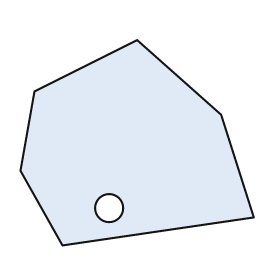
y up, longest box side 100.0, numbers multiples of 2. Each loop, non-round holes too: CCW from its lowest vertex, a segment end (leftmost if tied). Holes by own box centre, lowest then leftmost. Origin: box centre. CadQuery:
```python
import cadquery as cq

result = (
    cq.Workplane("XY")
    .moveTo(-32.0, -44.0)
    .lineTo(50.0, -32.0)
    .lineTo(36.0, 12.0)
    .lineTo(0.0, 44.0)
    .lineTo(-44.0, 22.0)
    .lineTo(-50.0, -12.0)
    .close()
    .moveTo(-12.0, -28.0)
    .circle(6.0)
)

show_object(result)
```